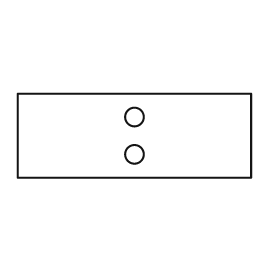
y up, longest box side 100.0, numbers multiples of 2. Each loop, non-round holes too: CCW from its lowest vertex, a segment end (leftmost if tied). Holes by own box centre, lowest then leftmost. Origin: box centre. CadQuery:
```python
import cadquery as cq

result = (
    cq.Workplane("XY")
    .moveTo(-50.0, -18.0)
    .lineTo(50.0, -18.0)
    .lineTo(50.0, 18.0)
    .lineTo(-50.0, 18.0)
    .close()
    .moveTo(0.0, -8.0)
    .circle(4.0)
    .moveTo(0.0, 8.0)
    .circle(4.0)
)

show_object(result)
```